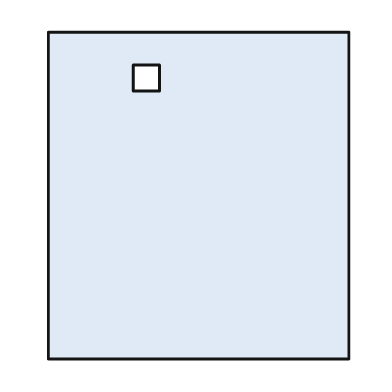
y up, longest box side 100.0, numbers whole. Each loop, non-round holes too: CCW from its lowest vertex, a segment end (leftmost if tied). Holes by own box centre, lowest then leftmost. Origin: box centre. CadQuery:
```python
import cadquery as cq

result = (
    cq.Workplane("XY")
    .moveTo(-46.0, -50.0)
    .lineTo(46.0, -50.0)
    .lineTo(46.0, 50.0)
    .lineTo(-46.0, 50.0)
    .close()
    .moveTo(-20.0, 32.0)
    .lineTo(-12.0, 32.0)
    .lineTo(-12.0, 40.0)
    .lineTo(-20.0, 40.0)
    .close()
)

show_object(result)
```